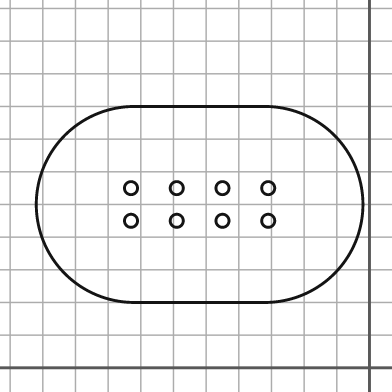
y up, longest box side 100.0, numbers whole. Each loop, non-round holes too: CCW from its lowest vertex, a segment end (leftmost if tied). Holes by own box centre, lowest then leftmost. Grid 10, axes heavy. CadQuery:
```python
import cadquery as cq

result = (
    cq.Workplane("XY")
    .moveTo(-72.0, 20.0)
    .lineTo(-32.0, 20.0)
    .threePointArc((-2.0, 50.0), (-32.0, 80.0))
    .lineTo(-72.0, 80.0)
    .threePointArc((-102.0, 50.0), (-72.0, 20.0))
    .close()
    .moveTo(-73.0, 45.0)
    .circle(2.0)
    .moveTo(-59.0, 45.0)
    .circle(2.0)
    .moveTo(-45.0, 45.0)
    .circle(2.0)
    .moveTo(-31.0, 45.0)
    .circle(2.0)
    .moveTo(-73.0, 55.0)
    .circle(2.0)
    .moveTo(-59.0, 55.0)
    .circle(2.0)
    .moveTo(-45.0, 55.0)
    .circle(2.0)
    .moveTo(-31.0, 55.0)
    .circle(2.0)
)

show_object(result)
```